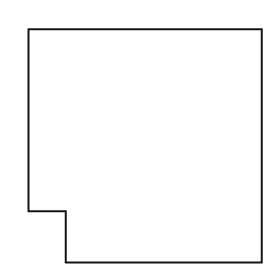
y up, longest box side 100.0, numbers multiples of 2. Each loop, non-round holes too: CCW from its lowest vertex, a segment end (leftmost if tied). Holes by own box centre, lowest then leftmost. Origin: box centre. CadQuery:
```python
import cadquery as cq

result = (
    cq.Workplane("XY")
    .moveTo(-34.0, -50.0)
    .lineTo(50.0, -50.0)
    .lineTo(50.0, 50.0)
    .lineTo(-50.0, 50.0)
    .lineTo(-50.0, -28.0)
    .lineTo(-34.0, -28.0)
    .close()
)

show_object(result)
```